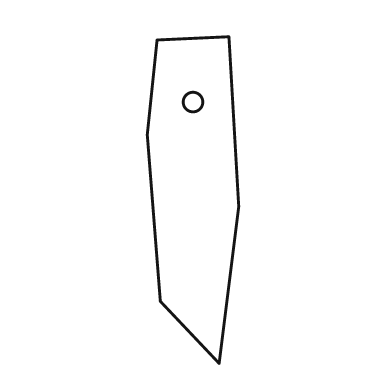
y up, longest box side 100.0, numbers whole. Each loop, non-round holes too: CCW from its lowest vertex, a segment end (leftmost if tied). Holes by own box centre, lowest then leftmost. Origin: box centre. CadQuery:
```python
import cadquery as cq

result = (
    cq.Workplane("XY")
    .moveTo(8.0, -50.0)
    .lineTo(14.0, -2.0)
    .lineTo(11.0, 50.0)
    .lineTo(-11.0, 49.0)
    .lineTo(-14.0, 20.0)
    .lineTo(-10.0, -31.0)
    .close()
    .moveTo(0.0, 30.0)
    .circle(3.0)
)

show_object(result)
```